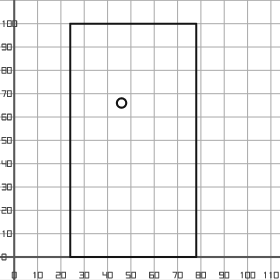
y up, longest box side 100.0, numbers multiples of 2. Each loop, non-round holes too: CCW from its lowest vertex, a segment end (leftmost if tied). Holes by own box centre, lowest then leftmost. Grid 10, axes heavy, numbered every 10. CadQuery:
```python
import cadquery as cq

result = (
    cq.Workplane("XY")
    .moveTo(24.0, 0.0)
    .lineTo(78.0, 0.0)
    .lineTo(78.0, 100.0)
    .lineTo(24.0, 100.0)
    .close()
    .moveTo(46.0, 66.0)
    .circle(2.0)
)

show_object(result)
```